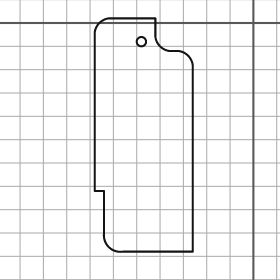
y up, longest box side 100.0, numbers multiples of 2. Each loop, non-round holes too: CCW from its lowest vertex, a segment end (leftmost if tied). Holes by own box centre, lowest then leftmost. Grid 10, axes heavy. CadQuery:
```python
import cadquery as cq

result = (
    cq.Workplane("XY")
    .moveTo(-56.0, -98.0)
    .lineTo(-26.0, -98.0)
    .lineTo(-26.0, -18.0)
    .threePointArc((-28.0, -14.0), (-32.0, -12.0))
    .lineTo(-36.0, -12.0)
    .threePointArc((-40.0, -10.0), (-42.0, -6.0))
    .lineTo(-42.0, 2.0)
    .lineTo(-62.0, 2.0)
    .threePointArc((-66.0, 0.0), (-68.0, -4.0))
    .lineTo(-68.0, -72.0)
    .lineTo(-64.0, -72.0)
    .lineTo(-64.0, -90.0)
    .threePointArc((-62.0, -96.0), (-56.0, -98.0))
    .close()
    .moveTo(-48.0, -8.0)
    .circle(2.0)
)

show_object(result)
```